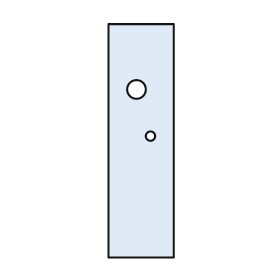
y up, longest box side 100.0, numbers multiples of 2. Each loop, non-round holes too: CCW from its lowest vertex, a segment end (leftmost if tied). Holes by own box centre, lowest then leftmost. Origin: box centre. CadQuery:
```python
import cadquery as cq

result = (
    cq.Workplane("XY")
    .moveTo(-14.0, -50.0)
    .lineTo(14.0, -50.0)
    .lineTo(14.0, 50.0)
    .lineTo(-14.0, 50.0)
    .close()
    .moveTo(4.0, 2.0)
    .circle(2.0)
    .moveTo(-2.0, 22.0)
    .circle(4.0)
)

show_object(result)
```